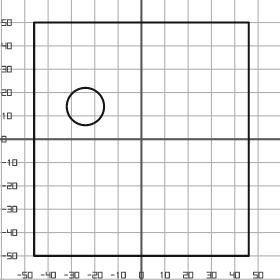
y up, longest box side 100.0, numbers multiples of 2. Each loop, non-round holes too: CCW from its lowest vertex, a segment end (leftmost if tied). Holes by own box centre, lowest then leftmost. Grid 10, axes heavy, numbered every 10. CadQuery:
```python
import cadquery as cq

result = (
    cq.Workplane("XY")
    .moveTo(-46.0, -50.0)
    .lineTo(46.0, -50.0)
    .lineTo(46.0, 50.0)
    .lineTo(-46.0, 50.0)
    .close()
    .moveTo(-24.0, 14.0)
    .circle(8.0)
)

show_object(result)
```